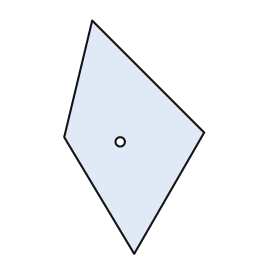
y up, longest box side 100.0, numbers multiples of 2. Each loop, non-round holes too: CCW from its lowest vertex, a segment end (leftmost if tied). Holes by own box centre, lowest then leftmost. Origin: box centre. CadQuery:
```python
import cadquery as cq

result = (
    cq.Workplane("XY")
    .moveTo(0.0, -50.0)
    .lineTo(30.0, 2.0)
    .lineTo(-18.0, 50.0)
    .lineTo(-30.0, 0.0)
    .close()
    .moveTo(-6.0, -2.0)
    .circle(2.0)
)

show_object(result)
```